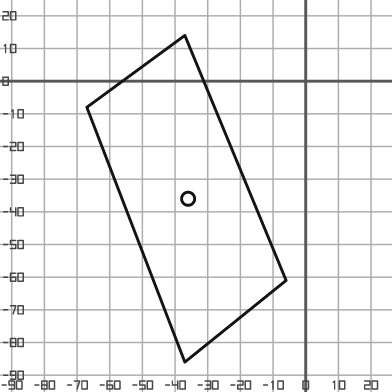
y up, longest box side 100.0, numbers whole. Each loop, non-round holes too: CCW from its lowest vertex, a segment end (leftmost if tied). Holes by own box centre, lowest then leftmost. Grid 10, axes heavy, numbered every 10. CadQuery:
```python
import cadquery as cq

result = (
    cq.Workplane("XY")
    .moveTo(-37.0, -86.0)
    .lineTo(-6.0, -61.0)
    .lineTo(-37.0, 14.0)
    .lineTo(-67.0, -8.0)
    .close()
    .moveTo(-36.0, -36.0)
    .circle(2.0)
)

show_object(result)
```